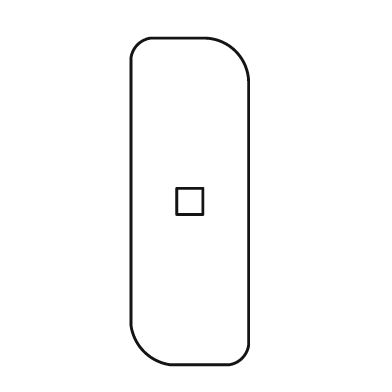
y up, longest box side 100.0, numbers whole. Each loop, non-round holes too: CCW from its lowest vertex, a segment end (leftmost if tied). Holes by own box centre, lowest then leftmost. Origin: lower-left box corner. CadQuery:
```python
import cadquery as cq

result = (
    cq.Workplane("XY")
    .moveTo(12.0, 0.0)
    .lineTo(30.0, 0.0)
    .threePointArc((34.0, 2.0), (36.0, 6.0))
    .lineTo(36.0, 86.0)
    .threePointArc((32.0, 96.0), (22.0, 100.0))
    .lineTo(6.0, 100.0)
    .threePointArc((2.0, 98.0), (0.0, 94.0))
    .lineTo(0.0, 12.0)
    .threePointArc((4.0, 4.0), (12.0, 0.0))
    .close()
    .moveTo(14.0, 46.0)
    .lineTo(22.0, 46.0)
    .lineTo(22.0, 54.0)
    .lineTo(14.0, 54.0)
    .close()
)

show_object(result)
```